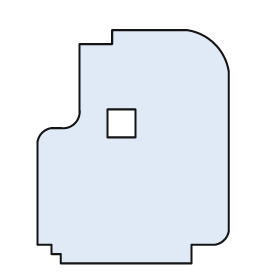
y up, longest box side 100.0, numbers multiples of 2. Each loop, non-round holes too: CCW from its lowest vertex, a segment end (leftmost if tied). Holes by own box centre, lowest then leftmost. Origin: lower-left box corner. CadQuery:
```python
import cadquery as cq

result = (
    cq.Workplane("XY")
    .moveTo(10.0, 0.0)
    .lineTo(66.0, 0.0)
    .lineTo(66.0, 8.0)
    .lineTo(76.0, 8.0)
    .threePointArc((80.0, 10.0), (82.0, 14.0))
    .lineTo(82.0, 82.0)
    .threePointArc((76.0, 94.0), (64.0, 100.0))
    .lineTo(32.0, 100.0)
    .lineTo(32.0, 94.0)
    .lineTo(18.0, 94.0)
    .lineTo(18.0, 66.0)
    .threePointArc((16.0, 60.0), (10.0, 58.0))
    .lineTo(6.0, 58.0)
    .threePointArc((2.0, 56.0), (0.0, 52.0))
    .lineTo(0.0, 8.0)
    .lineTo(6.0, 8.0)
    .lineTo(6.0, 4.0)
    .lineTo(10.0, 4.0)
    .close()
    .moveTo(30.0, 54.0)
    .lineTo(42.0, 54.0)
    .lineTo(42.0, 66.0)
    .lineTo(30.0, 66.0)
    .close()
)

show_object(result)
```